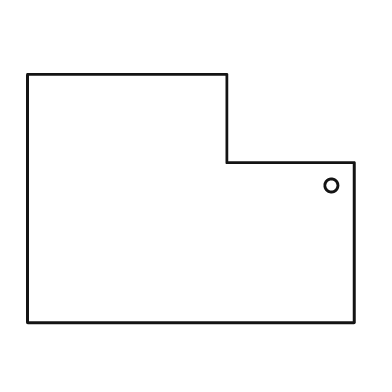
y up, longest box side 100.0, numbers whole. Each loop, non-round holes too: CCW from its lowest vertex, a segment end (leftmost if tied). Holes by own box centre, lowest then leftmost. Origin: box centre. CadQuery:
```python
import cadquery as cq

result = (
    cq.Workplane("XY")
    .moveTo(-50.0, -38.0)
    .lineTo(50.0, -38.0)
    .lineTo(50.0, 11.0)
    .lineTo(11.0, 11.0)
    .lineTo(11.0, 38.0)
    .lineTo(-50.0, 38.0)
    .close()
    .moveTo(43.0, 4.0)
    .circle(2.0)
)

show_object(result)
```